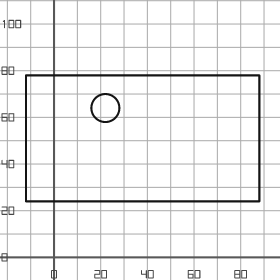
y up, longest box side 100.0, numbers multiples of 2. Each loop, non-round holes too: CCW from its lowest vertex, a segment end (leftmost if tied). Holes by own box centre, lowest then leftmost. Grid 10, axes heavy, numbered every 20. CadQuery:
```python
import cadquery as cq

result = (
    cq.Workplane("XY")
    .moveTo(-12.0, 24.0)
    .lineTo(88.0, 24.0)
    .lineTo(88.0, 78.0)
    .lineTo(-12.0, 78.0)
    .close()
    .moveTo(22.0, 64.0)
    .circle(6.0)
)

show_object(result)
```